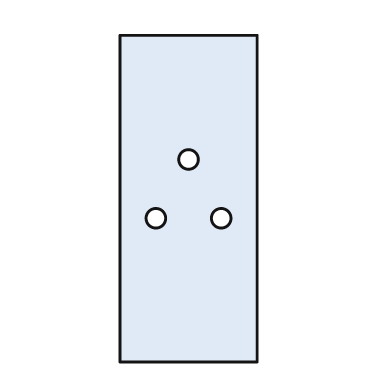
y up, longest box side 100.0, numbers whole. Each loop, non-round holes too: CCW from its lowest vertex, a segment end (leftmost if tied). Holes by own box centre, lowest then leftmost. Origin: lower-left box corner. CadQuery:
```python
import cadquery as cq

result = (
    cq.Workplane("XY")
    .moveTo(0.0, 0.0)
    .lineTo(42.0, 0.0)
    .lineTo(42.0, 100.0)
    .lineTo(0.0, 100.0)
    .close()
    .moveTo(11.0, 44.0)
    .circle(3.0)
    .moveTo(31.0, 44.0)
    .circle(3.0)
    .moveTo(21.0, 62.0)
    .circle(3.0)
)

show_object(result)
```